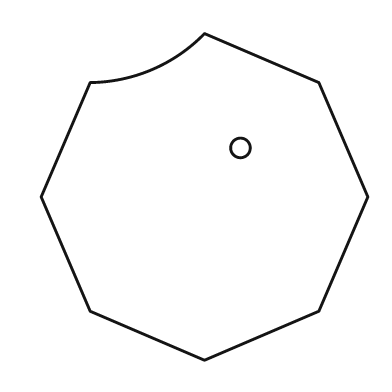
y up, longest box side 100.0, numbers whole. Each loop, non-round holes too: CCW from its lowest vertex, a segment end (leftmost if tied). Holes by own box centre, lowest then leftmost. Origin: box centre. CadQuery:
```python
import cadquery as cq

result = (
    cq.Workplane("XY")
    .moveTo(0.0, -50.0)
    .lineTo(35.0, -35.0)
    .lineTo(50.0, 0.0)
    .lineTo(35.0, 35.0)
    .lineTo(0.0, 50.0)
    .threePointArc((-16.0, 39.0), (-35.0, 35.0))
    .lineTo(-50.0, 0.0)
    .lineTo(-35.0, -35.0)
    .close()
    .moveTo(11.0, 15.0)
    .circle(3.0)
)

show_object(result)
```